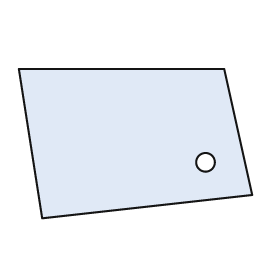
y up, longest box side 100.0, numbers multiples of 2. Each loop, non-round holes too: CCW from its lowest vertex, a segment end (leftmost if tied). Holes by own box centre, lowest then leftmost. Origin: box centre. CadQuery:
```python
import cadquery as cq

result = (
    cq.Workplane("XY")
    .moveTo(-40.0, -32.0)
    .lineTo(50.0, -22.0)
    .lineTo(38.0, 32.0)
    .lineTo(-50.0, 32.0)
    .close()
    .moveTo(30.0, -8.0)
    .circle(4.0)
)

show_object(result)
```